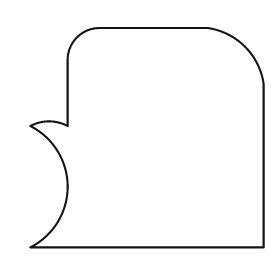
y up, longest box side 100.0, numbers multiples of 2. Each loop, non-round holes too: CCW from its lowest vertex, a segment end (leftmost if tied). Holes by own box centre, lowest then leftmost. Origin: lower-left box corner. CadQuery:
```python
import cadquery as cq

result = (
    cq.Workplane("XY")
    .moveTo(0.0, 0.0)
    .lineTo(100.0, 0.0)
    .lineTo(100.0, 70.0)
    .threePointArc((92.0, 86.0), (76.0, 94.0))
    .lineTo(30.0, 94.0)
    .threePointArc((20.0, 90.0), (16.0, 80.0))
    .lineTo(16.0, 52.0)
    .threePointArc((8.0, 54.0), (0.0, 52.0))
    .threePointArc((16.0, 26.0), (0.0, 0.0))
    .close()
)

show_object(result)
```